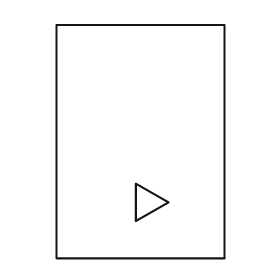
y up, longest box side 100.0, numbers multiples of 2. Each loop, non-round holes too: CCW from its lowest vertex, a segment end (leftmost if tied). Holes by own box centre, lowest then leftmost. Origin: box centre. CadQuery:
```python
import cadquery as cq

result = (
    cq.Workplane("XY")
    .moveTo(-36.0, -50.0)
    .lineTo(36.0, -50.0)
    .lineTo(36.0, 50.0)
    .lineTo(-36.0, 50.0)
    .close()
    .moveTo(-2.0, -34.0)
    .lineTo(12.0, -26.0)
    .lineTo(-2.0, -18.0)
    .close()
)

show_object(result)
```